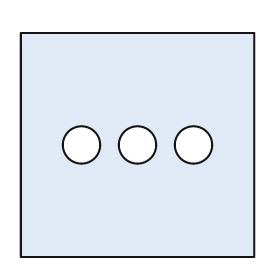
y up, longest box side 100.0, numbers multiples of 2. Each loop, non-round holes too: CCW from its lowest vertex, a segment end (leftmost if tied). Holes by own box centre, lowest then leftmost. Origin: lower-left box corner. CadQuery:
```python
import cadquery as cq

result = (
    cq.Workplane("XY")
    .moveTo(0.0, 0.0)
    .lineTo(100.0, 0.0)
    .lineTo(100.0, 96.0)
    .lineTo(0.0, 96.0)
    .close()
    .moveTo(26.0, 48.0)
    .circle(8.0)
    .moveTo(50.0, 48.0)
    .circle(8.0)
    .moveTo(74.0, 48.0)
    .circle(8.0)
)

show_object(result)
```